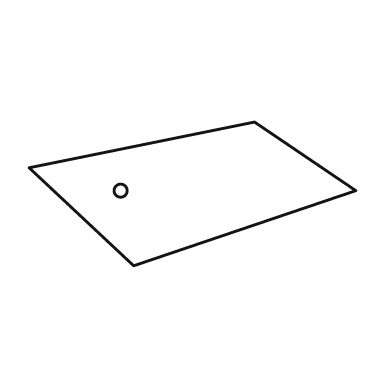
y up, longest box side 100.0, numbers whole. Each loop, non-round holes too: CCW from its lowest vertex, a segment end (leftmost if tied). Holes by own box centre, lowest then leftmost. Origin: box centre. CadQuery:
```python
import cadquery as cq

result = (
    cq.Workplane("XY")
    .moveTo(-18.0, -22.0)
    .lineTo(50.0, 1.0)
    .lineTo(19.0, 22.0)
    .lineTo(-50.0, 8.0)
    .close()
    .moveTo(-22.0, 1.0)
    .circle(2.0)
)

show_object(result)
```